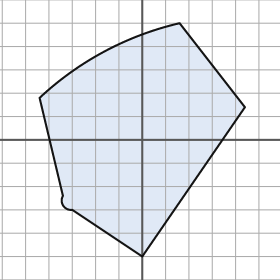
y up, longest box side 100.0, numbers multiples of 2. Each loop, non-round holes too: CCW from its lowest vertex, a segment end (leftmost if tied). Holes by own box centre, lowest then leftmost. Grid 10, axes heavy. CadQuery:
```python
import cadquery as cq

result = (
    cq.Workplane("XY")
    .moveTo(0.0, -50.0)
    .lineTo(44.0, 14.0)
    .lineTo(16.0, 50.0)
    .threePointArc((-16.0, 38.0), (-44.0, 18.0))
    .lineTo(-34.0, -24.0)
    .threePointArc((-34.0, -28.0), (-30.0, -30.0))
    .close()
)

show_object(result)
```